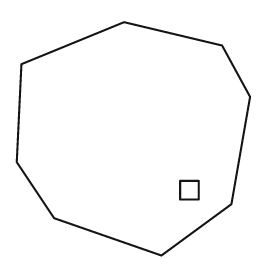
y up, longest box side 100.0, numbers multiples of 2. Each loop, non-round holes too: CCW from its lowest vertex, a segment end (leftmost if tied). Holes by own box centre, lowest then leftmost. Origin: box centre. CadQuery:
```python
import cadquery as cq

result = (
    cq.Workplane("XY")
    .moveTo(12.0, -50.0)
    .lineTo(42.0, -28.0)
    .lineTo(50.0, 18.0)
    .lineTo(38.0, 40.0)
    .lineTo(-4.0, 50.0)
    .lineTo(-48.0, 32.0)
    .lineTo(-50.0, -10.0)
    .lineTo(-34.0, -34.0)
    .close()
    .moveTo(20.0, -26.0)
    .lineTo(28.0, -26.0)
    .lineTo(28.0, -18.0)
    .lineTo(20.0, -18.0)
    .close()
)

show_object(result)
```